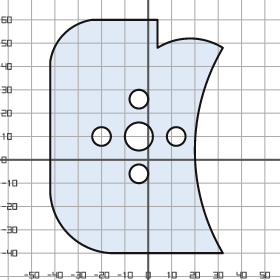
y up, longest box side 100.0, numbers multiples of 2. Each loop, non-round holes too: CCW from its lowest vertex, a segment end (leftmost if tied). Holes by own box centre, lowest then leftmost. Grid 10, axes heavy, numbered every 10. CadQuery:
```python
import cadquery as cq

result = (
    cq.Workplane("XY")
    .moveTo(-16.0, -40.0)
    .lineTo(32.0, -40.0)
    .threePointArc((20.0, 4.0), (32.0, 48.0))
    .threePointArc((18.0, 52.0), (4.0, 48.0))
    .lineTo(4.0, 60.0)
    .lineTo(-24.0, 60.0)
    .threePointArc((-36.0, 54.0), (-42.0, 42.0))
    .lineTo(-42.0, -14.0)
    .threePointArc((-34.0, -32.0), (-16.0, -40.0))
    .close()
    .moveTo(-4.0, -6.0)
    .circle(4.0)
    .moveTo(-20.0, 10.0)
    .circle(4.0)
    .moveTo(-4.0, 10.0)
    .circle(6.0)
    .moveTo(12.0, 10.0)
    .circle(4.0)
    .moveTo(-4.0, 26.0)
    .circle(4.0)
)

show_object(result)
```